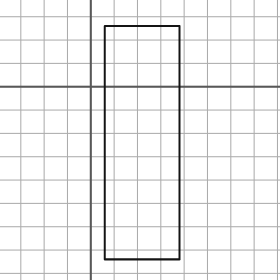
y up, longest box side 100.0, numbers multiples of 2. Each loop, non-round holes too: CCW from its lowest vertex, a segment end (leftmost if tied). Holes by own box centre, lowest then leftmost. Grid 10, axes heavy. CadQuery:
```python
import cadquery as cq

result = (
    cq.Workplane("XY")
    .moveTo(6.0, -74.0)
    .lineTo(38.0, -74.0)
    .lineTo(38.0, 26.0)
    .lineTo(6.0, 26.0)
    .close()
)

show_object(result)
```